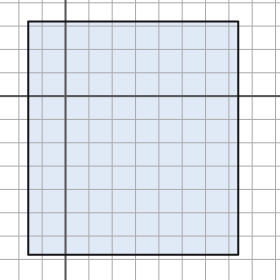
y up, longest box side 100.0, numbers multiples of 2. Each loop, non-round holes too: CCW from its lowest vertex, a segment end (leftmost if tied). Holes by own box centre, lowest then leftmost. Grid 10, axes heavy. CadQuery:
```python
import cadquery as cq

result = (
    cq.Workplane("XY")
    .moveTo(-16.0, -68.0)
    .lineTo(74.0, -68.0)
    .lineTo(74.0, 32.0)
    .lineTo(-16.0, 32.0)
    .close()
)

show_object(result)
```